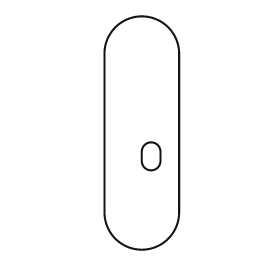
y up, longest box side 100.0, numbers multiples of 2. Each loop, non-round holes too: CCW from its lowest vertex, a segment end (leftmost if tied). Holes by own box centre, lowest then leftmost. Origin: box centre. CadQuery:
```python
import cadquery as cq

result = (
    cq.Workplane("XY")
    .moveTo(-16.0, -34.0)
    .threePointArc((0.0, -50.0), (16.0, -34.0))
    .lineTo(16.0, 34.0)
    .threePointArc((0.0, 50.0), (-16.0, 34.0))
    .close()
    .moveTo(0.0, -12.0)
    .threePointArc((4.0, -16.0), (8.0, -12.0))
    .lineTo(8.0, -8.0)
    .threePointArc((4.0, -4.0), (0.0, -8.0))
    .close()
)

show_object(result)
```